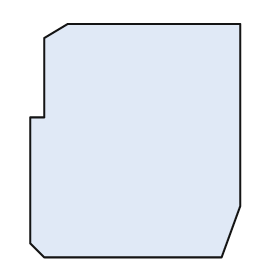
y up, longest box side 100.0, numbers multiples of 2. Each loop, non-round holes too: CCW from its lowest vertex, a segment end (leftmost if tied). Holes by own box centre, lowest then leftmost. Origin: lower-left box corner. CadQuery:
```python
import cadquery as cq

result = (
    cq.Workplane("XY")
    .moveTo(6.0, 0.0)
    .lineTo(82.0, 0.0)
    .lineTo(90.0, 22.0)
    .lineTo(90.0, 100.0)
    .lineTo(16.0, 100.0)
    .lineTo(6.0, 94.0)
    .lineTo(6.0, 60.0)
    .lineTo(0.0, 60.0)
    .lineTo(0.0, 6.0)
    .close()
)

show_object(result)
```